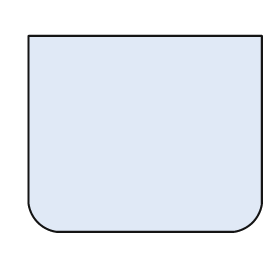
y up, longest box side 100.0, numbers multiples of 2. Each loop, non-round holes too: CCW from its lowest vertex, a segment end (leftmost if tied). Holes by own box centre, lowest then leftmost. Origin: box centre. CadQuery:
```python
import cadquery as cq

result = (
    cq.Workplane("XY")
    .moveTo(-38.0, -42.0)
    .lineTo(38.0, -42.0)
    .threePointArc((46.0, -38.0), (50.0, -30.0))
    .lineTo(50.0, 42.0)
    .lineTo(-50.0, 42.0)
    .lineTo(-50.0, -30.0)
    .threePointArc((-46.0, -38.0), (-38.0, -42.0))
    .close()
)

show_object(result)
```